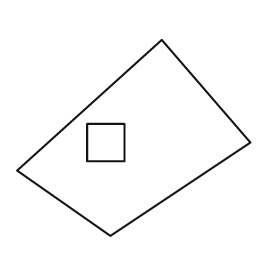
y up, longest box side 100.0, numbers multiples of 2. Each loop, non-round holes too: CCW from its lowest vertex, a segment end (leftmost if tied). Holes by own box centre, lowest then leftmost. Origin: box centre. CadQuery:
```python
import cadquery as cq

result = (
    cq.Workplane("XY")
    .moveTo(-10.0, -42.0)
    .lineTo(50.0, -2.0)
    .lineTo(12.0, 42.0)
    .lineTo(-50.0, -14.0)
    .close()
    .moveTo(-20.0, -10.0)
    .lineTo(-4.0, -10.0)
    .lineTo(-4.0, 6.0)
    .lineTo(-20.0, 6.0)
    .close()
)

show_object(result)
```